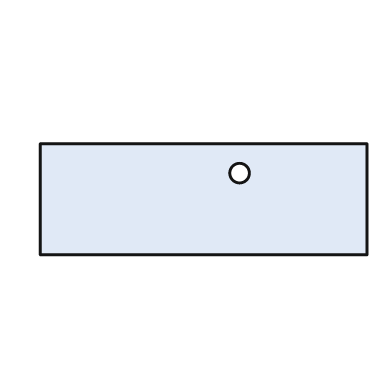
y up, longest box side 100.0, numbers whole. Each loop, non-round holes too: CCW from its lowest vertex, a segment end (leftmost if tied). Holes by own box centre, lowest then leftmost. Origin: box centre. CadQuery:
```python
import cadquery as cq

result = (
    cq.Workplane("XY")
    .moveTo(-50.0, -17.0)
    .lineTo(50.0, -17.0)
    .lineTo(50.0, 17.0)
    .lineTo(-50.0, 17.0)
    .close()
    .moveTo(11.0, 8.0)
    .circle(3.0)
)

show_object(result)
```